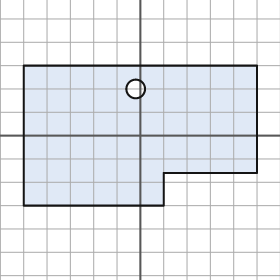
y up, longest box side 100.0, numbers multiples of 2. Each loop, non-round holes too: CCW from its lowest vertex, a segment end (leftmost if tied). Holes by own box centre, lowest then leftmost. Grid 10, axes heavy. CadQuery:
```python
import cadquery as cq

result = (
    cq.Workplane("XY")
    .moveTo(-50.0, -30.0)
    .lineTo(10.0, -30.0)
    .lineTo(10.0, -16.0)
    .lineTo(50.0, -16.0)
    .lineTo(50.0, 30.0)
    .lineTo(-50.0, 30.0)
    .close()
    .moveTo(-2.0, 20.0)
    .circle(4.0)
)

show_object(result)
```